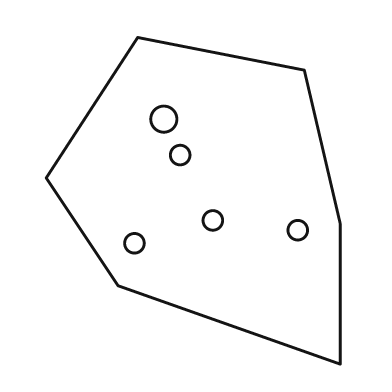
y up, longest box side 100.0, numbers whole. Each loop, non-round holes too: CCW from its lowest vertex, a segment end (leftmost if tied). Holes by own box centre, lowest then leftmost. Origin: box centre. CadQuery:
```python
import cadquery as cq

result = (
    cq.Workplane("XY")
    .moveTo(45.0, -50.0)
    .lineTo(45.0, -7.0)
    .lineTo(34.0, 40.0)
    .lineTo(-17.0, 50.0)
    .lineTo(-45.0, 7.0)
    .lineTo(-23.0, -26.0)
    .close()
    .moveTo(-18.0, -13.0)
    .circle(3.0)
    .moveTo(32.0, -9.0)
    .circle(3.0)
    .moveTo(6.0, -6.0)
    .circle(3.0)
    .moveTo(-4.0, 14.0)
    .circle(3.0)
    .moveTo(-9.0, 25.0)
    .circle(4.0)
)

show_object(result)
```